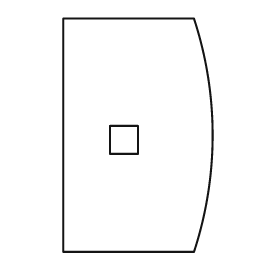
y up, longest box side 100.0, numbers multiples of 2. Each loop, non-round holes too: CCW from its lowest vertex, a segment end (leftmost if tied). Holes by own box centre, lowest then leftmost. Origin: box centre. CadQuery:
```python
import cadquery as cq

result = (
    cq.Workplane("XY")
    .moveTo(-32.0, -50.0)
    .lineTo(24.0, -50.0)
    .threePointArc((32.0, 0.0), (24.0, 50.0))
    .lineTo(-32.0, 50.0)
    .close()
    .moveTo(-12.0, -8.0)
    .lineTo(0.0, -8.0)
    .lineTo(0.0, 4.0)
    .lineTo(-12.0, 4.0)
    .close()
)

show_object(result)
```